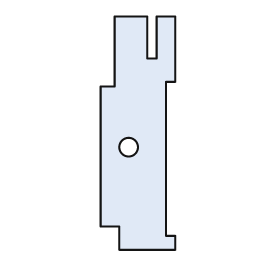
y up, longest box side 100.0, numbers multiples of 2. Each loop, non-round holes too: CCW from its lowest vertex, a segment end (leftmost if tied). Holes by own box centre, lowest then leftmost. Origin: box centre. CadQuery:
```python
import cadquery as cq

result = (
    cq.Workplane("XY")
    .moveTo(-8.0, -50.0)
    .lineTo(16.0, -50.0)
    .lineTo(16.0, -44.0)
    .lineTo(12.0, -44.0)
    .lineTo(12.0, 22.0)
    .lineTo(16.0, 22.0)
    .lineTo(16.0, 50.0)
    .lineTo(8.0, 50.0)
    .lineTo(8.0, 32.0)
    .lineTo(4.0, 32.0)
    .lineTo(4.0, 50.0)
    .lineTo(-10.0, 50.0)
    .lineTo(-10.0, 20.0)
    .lineTo(-16.0, 20.0)
    .lineTo(-16.0, -40.0)
    .lineTo(-8.0, -40.0)
    .close()
    .moveTo(-4.0, -6.0)
    .circle(4.0)
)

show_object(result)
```